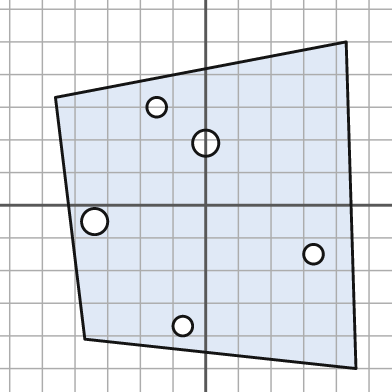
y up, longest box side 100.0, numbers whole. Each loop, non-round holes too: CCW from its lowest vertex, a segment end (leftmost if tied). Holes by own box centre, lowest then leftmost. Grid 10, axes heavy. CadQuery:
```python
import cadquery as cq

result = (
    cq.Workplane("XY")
    .moveTo(46.0, -50.0)
    .lineTo(43.0, 50.0)
    .lineTo(-46.0, 33.0)
    .lineTo(-37.0, -41.0)
    .close()
    .moveTo(-7.0, -37.0)
    .circle(3.0)
    .moveTo(33.0, -15.0)
    .circle(3.0)
    .moveTo(-34.0, -5.0)
    .circle(4.0)
    .moveTo(0.0, 19.0)
    .circle(4.0)
    .moveTo(-15.0, 30.0)
    .circle(3.0)
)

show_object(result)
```